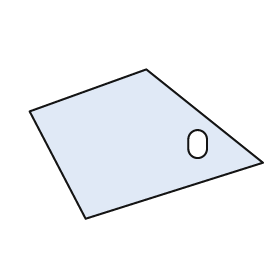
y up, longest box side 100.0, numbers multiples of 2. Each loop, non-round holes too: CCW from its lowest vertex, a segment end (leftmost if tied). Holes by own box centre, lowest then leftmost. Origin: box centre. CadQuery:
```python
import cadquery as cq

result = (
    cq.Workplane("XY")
    .moveTo(-26.0, -32.0)
    .lineTo(50.0, -8.0)
    .lineTo(0.0, 32.0)
    .lineTo(-50.0, 14.0)
    .close()
    .moveTo(18.0, -2.0)
    .threePointArc((22.0, -6.0), (26.0, -2.0))
    .lineTo(26.0, 2.0)
    .threePointArc((22.0, 6.0), (18.0, 2.0))
    .close()
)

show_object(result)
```